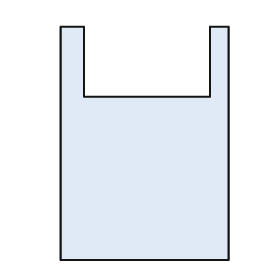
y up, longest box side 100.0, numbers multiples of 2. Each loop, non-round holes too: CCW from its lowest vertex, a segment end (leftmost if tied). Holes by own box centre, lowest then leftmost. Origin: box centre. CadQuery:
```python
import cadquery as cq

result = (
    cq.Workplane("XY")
    .moveTo(-36.0, -50.0)
    .lineTo(36.0, -50.0)
    .lineTo(36.0, 50.0)
    .lineTo(28.0, 50.0)
    .lineTo(28.0, 20.0)
    .lineTo(-26.0, 20.0)
    .lineTo(-26.0, 50.0)
    .lineTo(-36.0, 50.0)
    .close()
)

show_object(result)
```